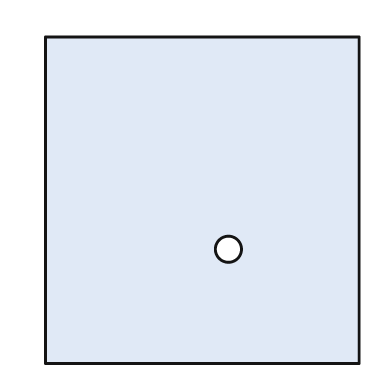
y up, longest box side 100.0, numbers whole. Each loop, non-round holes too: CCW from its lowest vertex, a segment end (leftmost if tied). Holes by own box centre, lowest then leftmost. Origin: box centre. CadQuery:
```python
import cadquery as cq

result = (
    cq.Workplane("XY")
    .moveTo(-48.0, -50.0)
    .lineTo(48.0, -50.0)
    .lineTo(48.0, 50.0)
    .lineTo(-48.0, 50.0)
    .close()
    .moveTo(8.0, -15.0)
    .circle(4.0)
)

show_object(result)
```